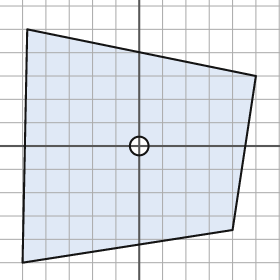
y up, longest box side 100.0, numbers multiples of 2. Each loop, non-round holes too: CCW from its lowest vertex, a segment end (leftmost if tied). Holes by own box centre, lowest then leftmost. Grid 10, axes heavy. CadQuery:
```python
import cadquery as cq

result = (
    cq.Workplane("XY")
    .moveTo(-50.0, -50.0)
    .lineTo(40.0, -36.0)
    .lineTo(50.0, 30.0)
    .lineTo(-48.0, 50.0)
    .close()
    .moveTo(0.0, 0.0)
    .circle(4.0)
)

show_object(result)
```